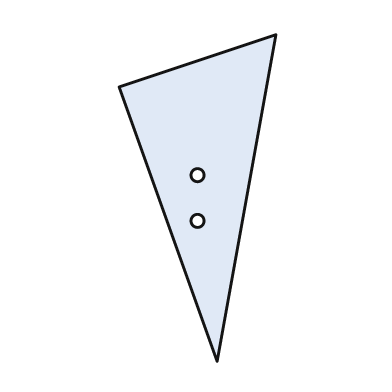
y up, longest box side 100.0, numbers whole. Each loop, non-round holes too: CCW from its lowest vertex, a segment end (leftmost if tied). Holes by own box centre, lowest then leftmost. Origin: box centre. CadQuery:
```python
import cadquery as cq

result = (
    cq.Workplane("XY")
    .moveTo(6.0, -50.0)
    .lineTo(24.0, 50.0)
    .lineTo(-24.0, 34.0)
    .close()
    .moveTo(0.0, -7.0)
    .circle(2.0)
    .moveTo(0.0, 7.0)
    .circle(2.0)
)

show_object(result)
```